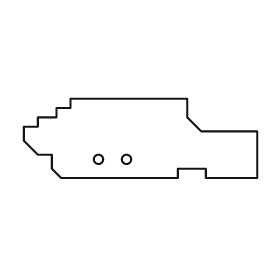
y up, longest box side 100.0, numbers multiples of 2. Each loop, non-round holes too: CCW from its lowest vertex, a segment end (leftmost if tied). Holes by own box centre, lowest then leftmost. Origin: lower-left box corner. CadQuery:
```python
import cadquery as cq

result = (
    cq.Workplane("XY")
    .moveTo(16.0, 0.0)
    .lineTo(66.0, 0.0)
    .lineTo(66.0, 4.0)
    .lineTo(78.0, 4.0)
    .lineTo(78.0, 0.0)
    .lineTo(100.0, 0.0)
    .lineTo(100.0, 20.0)
    .lineTo(76.0, 20.0)
    .lineTo(70.0, 26.0)
    .lineTo(70.0, 34.0)
    .lineTo(20.0, 34.0)
    .lineTo(20.0, 30.0)
    .lineTo(14.0, 30.0)
    .lineTo(14.0, 26.0)
    .lineTo(6.0, 26.0)
    .lineTo(6.0, 22.0)
    .lineTo(0.0, 22.0)
    .lineTo(0.0, 16.0)
    .lineTo(6.0, 10.0)
    .lineTo(12.0, 10.0)
    .lineTo(12.0, 4.0)
    .close()
    .moveTo(32.0, 8.0)
    .circle(2.0)
    .moveTo(44.0, 8.0)
    .circle(2.0)
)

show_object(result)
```